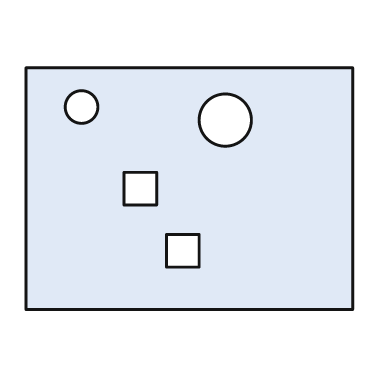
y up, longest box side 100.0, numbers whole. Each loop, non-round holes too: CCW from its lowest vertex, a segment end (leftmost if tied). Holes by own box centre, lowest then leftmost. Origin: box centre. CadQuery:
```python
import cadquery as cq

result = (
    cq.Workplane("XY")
    .moveTo(-50.0, -37.0)
    .lineTo(50.0, -37.0)
    .lineTo(50.0, 37.0)
    .lineTo(-50.0, 37.0)
    .close()
    .moveTo(-7.0, -24.0)
    .lineTo(3.0, -24.0)
    .lineTo(3.0, -14.0)
    .lineTo(-7.0, -14.0)
    .close()
    .moveTo(-20.0, -5.0)
    .lineTo(-10.0, -5.0)
    .lineTo(-10.0, 5.0)
    .lineTo(-20.0, 5.0)
    .close()
    .moveTo(11.0, 21.0)
    .circle(8.0)
    .moveTo(-33.0, 25.0)
    .circle(5.0)
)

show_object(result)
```